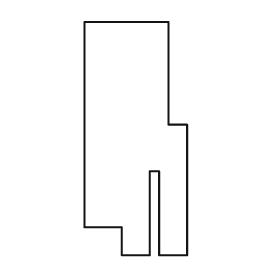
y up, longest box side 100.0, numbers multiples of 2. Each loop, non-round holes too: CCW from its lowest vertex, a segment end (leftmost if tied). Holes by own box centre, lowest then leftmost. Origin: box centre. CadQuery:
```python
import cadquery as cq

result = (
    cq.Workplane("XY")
    .moveTo(-6.0, -50.0)
    .lineTo(6.0, -50.0)
    .lineTo(6.0, -14.0)
    .lineTo(10.0, -14.0)
    .lineTo(10.0, -50.0)
    .lineTo(22.0, -50.0)
    .lineTo(22.0, 6.0)
    .lineTo(14.0, 6.0)
    .lineTo(14.0, 50.0)
    .lineTo(-22.0, 50.0)
    .lineTo(-22.0, -38.0)
    .lineTo(-6.0, -38.0)
    .close()
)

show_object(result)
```